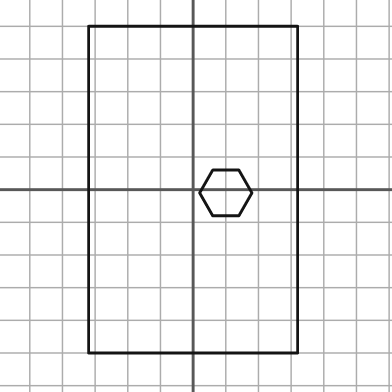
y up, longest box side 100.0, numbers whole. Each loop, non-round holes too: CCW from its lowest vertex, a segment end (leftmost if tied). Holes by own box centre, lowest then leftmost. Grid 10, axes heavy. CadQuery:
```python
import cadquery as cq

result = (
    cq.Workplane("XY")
    .moveTo(-32.0, -50.0)
    .lineTo(32.0, -50.0)
    .lineTo(32.0, 50.0)
    .lineTo(-32.0, 50.0)
    .close()
    .moveTo(6.0, -8.0)
    .lineTo(14.0, -8.0)
    .lineTo(18.0, -1.0)
    .lineTo(14.0, 6.0)
    .lineTo(6.0, 6.0)
    .lineTo(2.0, -1.0)
    .close()
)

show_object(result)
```